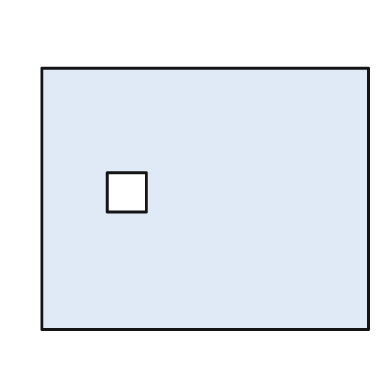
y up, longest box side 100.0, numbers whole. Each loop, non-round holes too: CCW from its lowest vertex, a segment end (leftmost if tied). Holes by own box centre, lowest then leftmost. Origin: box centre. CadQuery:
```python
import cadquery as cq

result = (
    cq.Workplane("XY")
    .moveTo(-50.0, -40.0)
    .lineTo(50.0, -40.0)
    .lineTo(50.0, 40.0)
    .lineTo(-50.0, 40.0)
    .close()
    .moveTo(-30.0, -4.0)
    .lineTo(-18.0, -4.0)
    .lineTo(-18.0, 8.0)
    .lineTo(-30.0, 8.0)
    .close()
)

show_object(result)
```